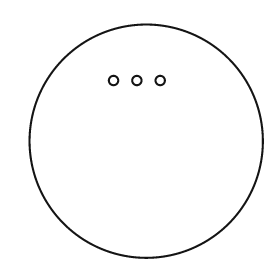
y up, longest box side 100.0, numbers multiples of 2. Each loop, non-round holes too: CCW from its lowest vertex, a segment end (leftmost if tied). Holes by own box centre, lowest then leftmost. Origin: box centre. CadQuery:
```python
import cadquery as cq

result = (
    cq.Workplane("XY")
    .moveTo(0.0, 0.0)
    .circle(50.0)
    .moveTo(-14.0, 26.0)
    .circle(2.0)
    .moveTo(-4.0, 26.0)
    .circle(2.0)
    .moveTo(6.0, 26.0)
    .circle(2.0)
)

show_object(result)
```